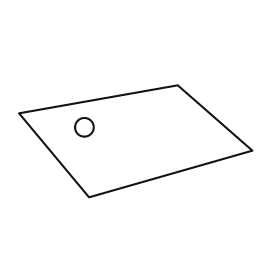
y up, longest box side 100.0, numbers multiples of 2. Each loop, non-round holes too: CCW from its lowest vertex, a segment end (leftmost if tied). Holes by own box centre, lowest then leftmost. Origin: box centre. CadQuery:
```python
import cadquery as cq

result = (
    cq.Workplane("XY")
    .moveTo(-20.0, -24.0)
    .lineTo(50.0, -4.0)
    .lineTo(18.0, 24.0)
    .lineTo(-50.0, 12.0)
    .close()
    .moveTo(-22.0, 6.0)
    .circle(4.0)
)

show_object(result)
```